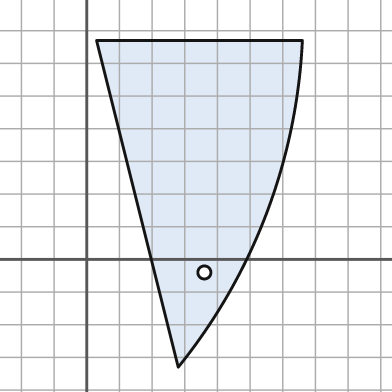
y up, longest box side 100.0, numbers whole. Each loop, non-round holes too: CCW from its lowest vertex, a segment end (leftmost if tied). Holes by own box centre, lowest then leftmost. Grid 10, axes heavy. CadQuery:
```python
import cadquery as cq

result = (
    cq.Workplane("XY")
    .moveTo(28.0, -33.0)
    .threePointArc((55.0, 14.0), (66.0, 67.0))
    .lineTo(3.0, 67.0)
    .close()
    .moveTo(36.0, -4.0)
    .circle(2.0)
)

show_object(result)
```